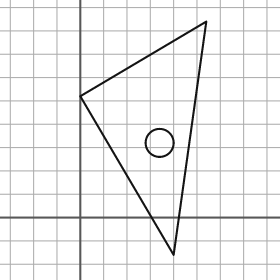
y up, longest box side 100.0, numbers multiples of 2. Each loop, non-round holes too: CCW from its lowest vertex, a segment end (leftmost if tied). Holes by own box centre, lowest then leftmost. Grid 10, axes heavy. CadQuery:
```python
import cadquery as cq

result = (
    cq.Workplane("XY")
    .moveTo(40.0, -16.0)
    .lineTo(54.0, 84.0)
    .lineTo(0.0, 52.0)
    .close()
    .moveTo(34.0, 32.0)
    .circle(6.0)
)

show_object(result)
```